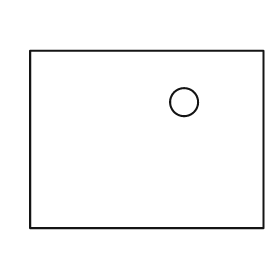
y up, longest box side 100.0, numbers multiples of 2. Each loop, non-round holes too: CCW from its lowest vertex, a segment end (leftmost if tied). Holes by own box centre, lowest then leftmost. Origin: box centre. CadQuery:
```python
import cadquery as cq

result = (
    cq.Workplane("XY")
    .moveTo(-50.0, -38.0)
    .lineTo(50.0, -38.0)
    .lineTo(50.0, 38.0)
    .lineTo(-50.0, 38.0)
    .close()
    .moveTo(16.0, 16.0)
    .circle(6.0)
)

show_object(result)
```